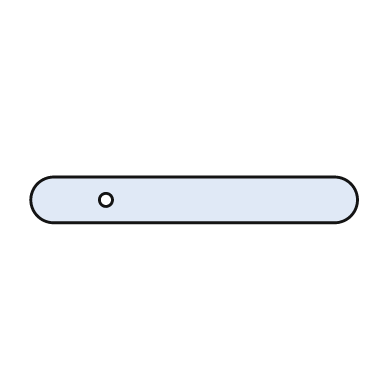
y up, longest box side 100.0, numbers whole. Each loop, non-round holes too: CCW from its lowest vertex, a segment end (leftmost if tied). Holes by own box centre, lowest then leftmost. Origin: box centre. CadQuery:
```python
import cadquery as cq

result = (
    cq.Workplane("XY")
    .moveTo(-43.0, -7.0)
    .lineTo(43.0, -7.0)
    .threePointArc((50.0, 0.0), (43.0, 7.0))
    .lineTo(-43.0, 7.0)
    .threePointArc((-50.0, 0.0), (-43.0, -7.0))
    .close()
    .moveTo(-27.0, 0.0)
    .circle(2.0)
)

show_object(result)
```